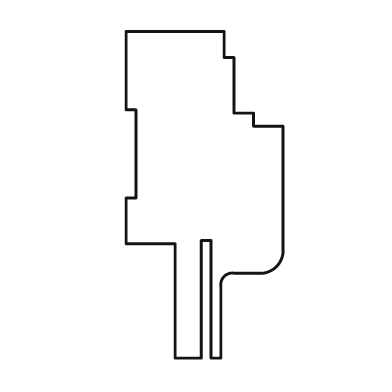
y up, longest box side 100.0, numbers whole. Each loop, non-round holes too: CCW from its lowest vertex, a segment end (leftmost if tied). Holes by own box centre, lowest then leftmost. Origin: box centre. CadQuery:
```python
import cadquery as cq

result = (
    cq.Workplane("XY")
    .moveTo(-9.0, -50.0)
    .lineTo(-1.0, -50.0)
    .lineTo(-1.0, -14.0)
    .lineTo(2.0, -14.0)
    .lineTo(2.0, -50.0)
    .lineTo(5.0, -50.0)
    .lineTo(5.0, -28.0)
    .threePointArc((6.0, -25.0), (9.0, -24.0))
    .lineTo(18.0, -24.0)
    .threePointArc((22.0, -22.0), (24.0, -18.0))
    .lineTo(24.0, 21.0)
    .lineTo(15.0, 21.0)
    .lineTo(15.0, 25.0)
    .lineTo(9.0, 25.0)
    .lineTo(9.0, 42.0)
    .lineTo(6.0, 42.0)
    .lineTo(6.0, 50.0)
    .lineTo(-24.0, 50.0)
    .lineTo(-24.0, 26.0)
    .lineTo(-21.0, 26.0)
    .lineTo(-21.0, -1.0)
    .lineTo(-24.0, -1.0)
    .lineTo(-24.0, -15.0)
    .lineTo(-9.0, -15.0)
    .close()
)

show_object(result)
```